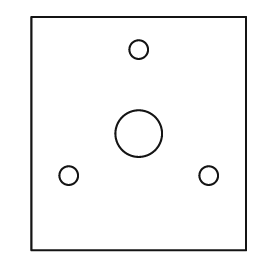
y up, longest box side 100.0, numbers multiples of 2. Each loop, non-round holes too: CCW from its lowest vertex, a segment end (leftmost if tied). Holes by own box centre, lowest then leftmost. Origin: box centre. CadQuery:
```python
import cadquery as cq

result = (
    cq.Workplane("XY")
    .moveTo(-46.0, -50.0)
    .lineTo(46.0, -50.0)
    .lineTo(46.0, 50.0)
    .lineTo(-46.0, 50.0)
    .close()
    .moveTo(-30.0, -18.0)
    .circle(4.0)
    .moveTo(30.0, -18.0)
    .circle(4.0)
    .moveTo(0.0, 0.0)
    .circle(10.0)
    .moveTo(0.0, 36.0)
    .circle(4.0)
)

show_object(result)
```